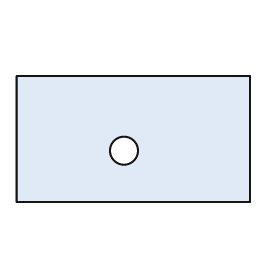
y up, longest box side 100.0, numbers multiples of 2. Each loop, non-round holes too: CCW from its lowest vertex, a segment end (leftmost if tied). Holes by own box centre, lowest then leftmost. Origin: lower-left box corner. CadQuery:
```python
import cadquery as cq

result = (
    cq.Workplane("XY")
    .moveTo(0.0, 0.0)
    .lineTo(100.0, 0.0)
    .lineTo(100.0, 54.0)
    .lineTo(0.0, 54.0)
    .close()
    .moveTo(46.0, 22.0)
    .circle(6.0)
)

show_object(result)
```